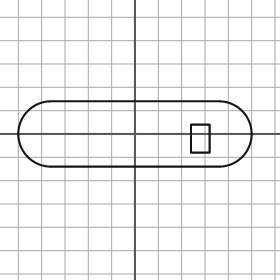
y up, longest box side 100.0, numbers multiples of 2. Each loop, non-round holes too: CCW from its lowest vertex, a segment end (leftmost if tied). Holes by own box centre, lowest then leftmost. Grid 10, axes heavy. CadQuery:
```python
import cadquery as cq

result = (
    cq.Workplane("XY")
    .moveTo(-36.0, -14.0)
    .lineTo(36.0, -14.0)
    .threePointArc((50.0, 0.0), (36.0, 14.0))
    .lineTo(-36.0, 14.0)
    .threePointArc((-50.0, 0.0), (-36.0, -14.0))
    .close()
    .moveTo(24.0, -8.0)
    .lineTo(32.0, -8.0)
    .lineTo(32.0, 4.0)
    .lineTo(24.0, 4.0)
    .close()
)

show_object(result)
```